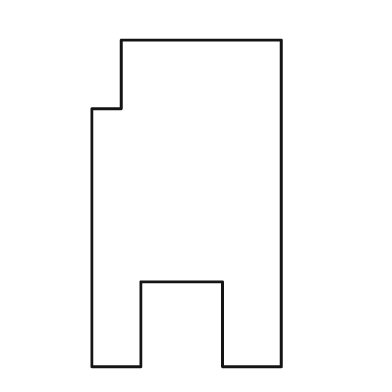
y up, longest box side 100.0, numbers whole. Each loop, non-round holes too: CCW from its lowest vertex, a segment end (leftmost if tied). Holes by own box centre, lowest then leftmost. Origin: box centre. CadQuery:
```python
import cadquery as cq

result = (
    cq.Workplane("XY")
    .moveTo(-29.0, -50.0)
    .lineTo(-14.0, -50.0)
    .lineTo(-14.0, -24.0)
    .lineTo(11.0, -24.0)
    .lineTo(11.0, -50.0)
    .lineTo(29.0, -50.0)
    .lineTo(29.0, 50.0)
    .lineTo(-20.0, 50.0)
    .lineTo(-20.0, 29.0)
    .lineTo(-29.0, 29.0)
    .close()
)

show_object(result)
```